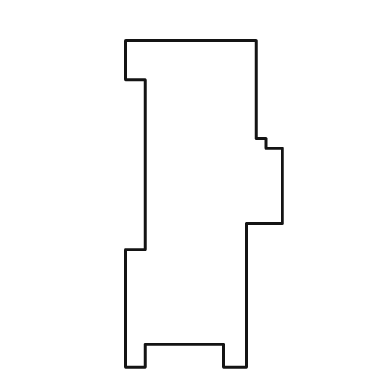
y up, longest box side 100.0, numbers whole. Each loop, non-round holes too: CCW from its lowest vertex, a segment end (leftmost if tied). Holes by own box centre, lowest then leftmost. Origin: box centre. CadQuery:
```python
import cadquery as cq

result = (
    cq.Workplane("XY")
    .moveTo(-24.0, -50.0)
    .lineTo(-18.0, -50.0)
    .lineTo(-18.0, -43.0)
    .lineTo(6.0, -43.0)
    .lineTo(6.0, -50.0)
    .lineTo(13.0, -50.0)
    .lineTo(13.0, -6.0)
    .lineTo(24.0, -6.0)
    .lineTo(24.0, 17.0)
    .lineTo(19.0, 17.0)
    .lineTo(19.0, 20.0)
    .lineTo(16.0, 20.0)
    .lineTo(16.0, 50.0)
    .lineTo(-24.0, 50.0)
    .lineTo(-24.0, 38.0)
    .lineTo(-18.0, 38.0)
    .lineTo(-18.0, -14.0)
    .lineTo(-24.0, -14.0)
    .close()
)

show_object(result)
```